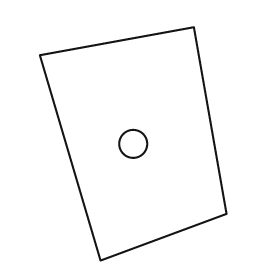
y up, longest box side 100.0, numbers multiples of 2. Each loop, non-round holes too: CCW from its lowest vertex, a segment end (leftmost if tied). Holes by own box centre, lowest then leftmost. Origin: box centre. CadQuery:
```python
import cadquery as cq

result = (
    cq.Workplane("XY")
    .moveTo(-14.0, -50.0)
    .lineTo(40.0, -30.0)
    .lineTo(26.0, 50.0)
    .lineTo(-40.0, 38.0)
    .close()
    .moveTo(0.0, 0.0)
    .circle(6.0)
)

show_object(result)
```